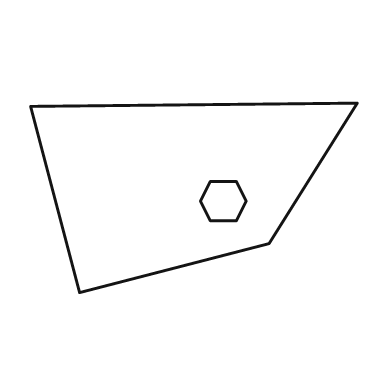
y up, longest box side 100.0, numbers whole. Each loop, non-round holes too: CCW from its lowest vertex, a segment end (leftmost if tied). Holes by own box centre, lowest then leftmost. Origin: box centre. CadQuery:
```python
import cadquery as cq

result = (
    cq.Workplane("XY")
    .moveTo(-35.0, -29.0)
    .lineTo(23.0, -14.0)
    .lineTo(50.0, 29.0)
    .lineTo(-50.0, 28.0)
    .close()
    .moveTo(5.0, -7.0)
    .lineTo(13.0, -7.0)
    .lineTo(16.0, -1.0)
    .lineTo(13.0, 5.0)
    .lineTo(5.0, 5.0)
    .lineTo(2.0, -1.0)
    .close()
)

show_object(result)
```